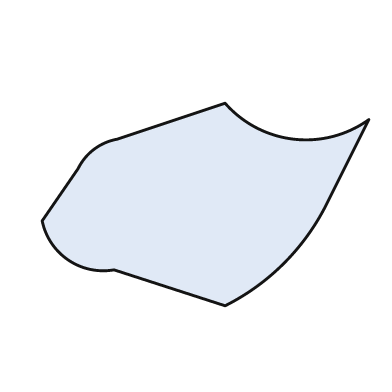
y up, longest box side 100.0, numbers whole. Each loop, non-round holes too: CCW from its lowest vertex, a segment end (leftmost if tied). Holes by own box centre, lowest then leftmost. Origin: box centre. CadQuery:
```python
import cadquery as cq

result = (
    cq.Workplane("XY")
    .moveTo(6.0, -31.0)
    .threePointArc((24.0, -18.0), (37.0, 0.0))
    .lineTo(50.0, 26.0)
    .threePointArc((27.0, 20.0), (6.0, 31.0))
    .lineTo(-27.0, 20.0)
    .threePointArc((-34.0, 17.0), (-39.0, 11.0))
    .lineTo(-50.0, -5.0)
    .threePointArc((-42.0, -17.0), (-28.0, -20.0))
    .close()
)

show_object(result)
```